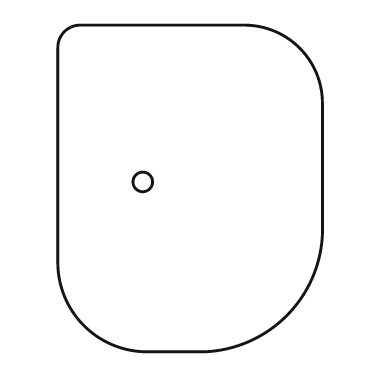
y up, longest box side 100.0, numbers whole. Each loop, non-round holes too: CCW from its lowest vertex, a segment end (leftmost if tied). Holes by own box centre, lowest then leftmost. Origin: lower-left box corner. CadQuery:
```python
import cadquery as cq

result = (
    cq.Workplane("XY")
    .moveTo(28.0, 0.0)
    .lineTo(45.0, 0.0)
    .threePointArc((70.0, 11.0), (81.0, 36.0))
    .lineTo(81.0, 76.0)
    .threePointArc((74.0, 93.0), (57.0, 100.0))
    .lineTo(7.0, 100.0)
    .threePointArc((2.0, 98.0), (0.0, 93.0))
    .lineTo(0.0, 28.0)
    .threePointArc((8.0, 8.0), (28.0, 0.0))
    .close()
    .moveTo(26.0, 52.0)
    .circle(3.0)
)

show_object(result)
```